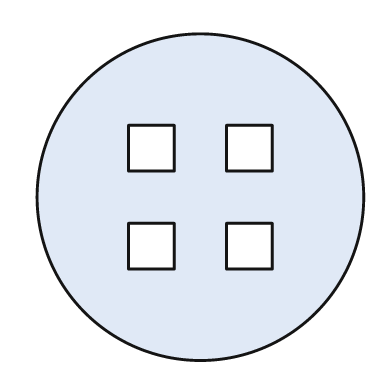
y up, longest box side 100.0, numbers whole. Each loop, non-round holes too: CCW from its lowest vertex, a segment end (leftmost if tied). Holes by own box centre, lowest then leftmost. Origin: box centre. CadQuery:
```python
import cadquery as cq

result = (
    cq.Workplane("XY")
    .moveTo(0.0, 0.0)
    .circle(50.0)
    .moveTo(-22.0, -22.0)
    .lineTo(-8.0, -22.0)
    .lineTo(-8.0, -8.0)
    .lineTo(-22.0, -8.0)
    .close()
    .moveTo(8.0, -22.0)
    .lineTo(22.0, -22.0)
    .lineTo(22.0, -8.0)
    .lineTo(8.0, -8.0)
    .close()
    .moveTo(-22.0, 8.0)
    .lineTo(-8.0, 8.0)
    .lineTo(-8.0, 22.0)
    .lineTo(-22.0, 22.0)
    .close()
    .moveTo(8.0, 8.0)
    .lineTo(22.0, 8.0)
    .lineTo(22.0, 22.0)
    .lineTo(8.0, 22.0)
    .close()
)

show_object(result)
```